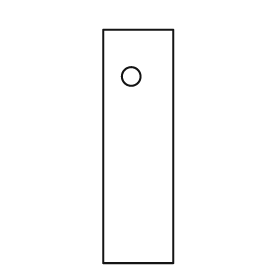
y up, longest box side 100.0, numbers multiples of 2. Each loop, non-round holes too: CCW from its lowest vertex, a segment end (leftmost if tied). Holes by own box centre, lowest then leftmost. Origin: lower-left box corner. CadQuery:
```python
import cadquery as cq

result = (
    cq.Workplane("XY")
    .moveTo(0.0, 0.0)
    .lineTo(30.0, 0.0)
    .lineTo(30.0, 100.0)
    .lineTo(0.0, 100.0)
    .close()
    .moveTo(12.0, 80.0)
    .circle(4.0)
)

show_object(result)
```